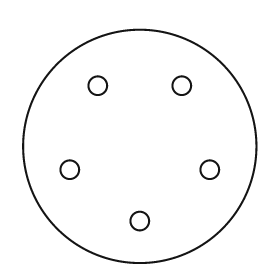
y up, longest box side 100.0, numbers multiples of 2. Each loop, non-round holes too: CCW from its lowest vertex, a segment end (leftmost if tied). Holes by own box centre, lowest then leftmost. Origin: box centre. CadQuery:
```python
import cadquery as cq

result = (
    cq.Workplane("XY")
    .moveTo(0.0, 0.0)
    .circle(50.0)
    .moveTo(0.0, -32.0)
    .circle(4.0)
    .moveTo(-30.0, -10.0)
    .circle(4.0)
    .moveTo(30.0, -10.0)
    .circle(4.0)
    .moveTo(-18.0, 26.0)
    .circle(4.0)
    .moveTo(18.0, 26.0)
    .circle(4.0)
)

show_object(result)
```